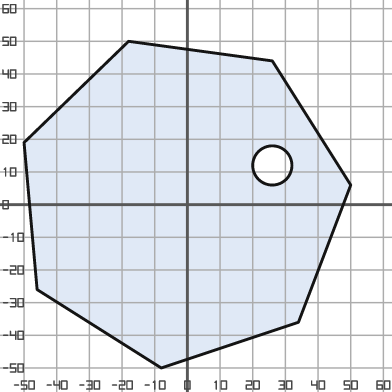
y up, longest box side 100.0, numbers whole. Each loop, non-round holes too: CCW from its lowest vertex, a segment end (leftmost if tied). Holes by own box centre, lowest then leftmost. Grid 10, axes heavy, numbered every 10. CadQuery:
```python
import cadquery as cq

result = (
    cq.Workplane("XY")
    .moveTo(-8.0, -50.0)
    .lineTo(34.0, -36.0)
    .lineTo(50.0, 6.0)
    .lineTo(26.0, 44.0)
    .lineTo(-18.0, 50.0)
    .lineTo(-50.0, 19.0)
    .lineTo(-46.0, -26.0)
    .close()
    .moveTo(26.0, 12.0)
    .circle(6.0)
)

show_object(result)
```